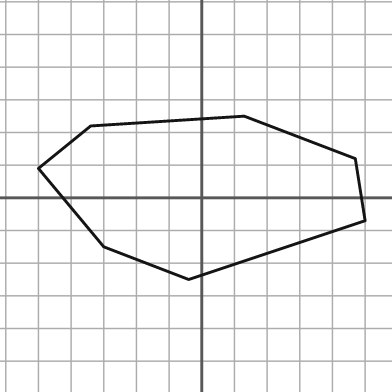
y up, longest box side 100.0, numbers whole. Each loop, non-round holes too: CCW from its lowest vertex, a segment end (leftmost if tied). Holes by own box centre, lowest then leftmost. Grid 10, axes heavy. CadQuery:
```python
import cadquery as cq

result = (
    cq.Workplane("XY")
    .moveTo(-4.0, -25.0)
    .lineTo(50.0, -7.0)
    .lineTo(47.0, 12.0)
    .lineTo(13.0, 25.0)
    .lineTo(-34.0, 22.0)
    .lineTo(-50.0, 9.0)
    .lineTo(-30.0, -15.0)
    .close()
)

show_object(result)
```